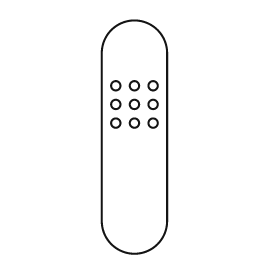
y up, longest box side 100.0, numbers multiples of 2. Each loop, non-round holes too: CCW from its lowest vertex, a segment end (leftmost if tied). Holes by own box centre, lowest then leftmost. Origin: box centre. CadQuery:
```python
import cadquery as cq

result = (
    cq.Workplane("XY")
    .moveTo(-14.0, -36.0)
    .threePointArc((0.0, -50.0), (14.0, -36.0))
    .lineTo(14.0, 36.0)
    .threePointArc((0.0, 50.0), (-14.0, 36.0))
    .close()
    .moveTo(-8.0, 6.0)
    .circle(2.0)
    .moveTo(0.0, 6.0)
    .circle(2.0)
    .moveTo(8.0, 6.0)
    .circle(2.0)
    .moveTo(-8.0, 14.0)
    .circle(2.0)
    .moveTo(0.0, 14.0)
    .circle(2.0)
    .moveTo(8.0, 14.0)
    .circle(2.0)
    .moveTo(-8.0, 22.0)
    .circle(2.0)
    .moveTo(0.0, 22.0)
    .circle(2.0)
    .moveTo(8.0, 22.0)
    .circle(2.0)
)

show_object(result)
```